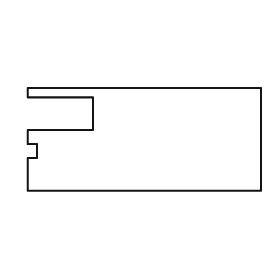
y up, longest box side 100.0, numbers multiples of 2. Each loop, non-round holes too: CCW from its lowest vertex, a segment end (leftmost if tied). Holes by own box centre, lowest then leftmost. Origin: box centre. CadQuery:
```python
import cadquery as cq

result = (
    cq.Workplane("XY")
    .moveTo(-50.0, -22.0)
    .lineTo(50.0, -22.0)
    .lineTo(50.0, 22.0)
    .lineTo(-50.0, 22.0)
    .lineTo(-50.0, 18.0)
    .lineTo(-22.0, 18.0)
    .lineTo(-22.0, 4.0)
    .lineTo(-50.0, 4.0)
    .lineTo(-50.0, -2.0)
    .lineTo(-46.0, -2.0)
    .lineTo(-46.0, -8.0)
    .lineTo(-50.0, -8.0)
    .close()
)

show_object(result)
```